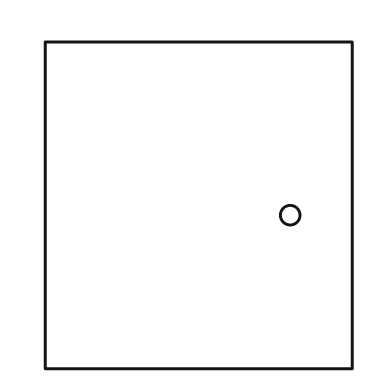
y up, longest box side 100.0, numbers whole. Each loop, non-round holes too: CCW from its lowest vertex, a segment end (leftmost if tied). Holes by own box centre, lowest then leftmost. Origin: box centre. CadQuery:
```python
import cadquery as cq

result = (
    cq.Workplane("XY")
    .moveTo(-47.0, -50.0)
    .lineTo(47.0, -50.0)
    .lineTo(47.0, 50.0)
    .lineTo(-47.0, 50.0)
    .close()
    .moveTo(28.0, -3.0)
    .circle(3.0)
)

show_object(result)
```